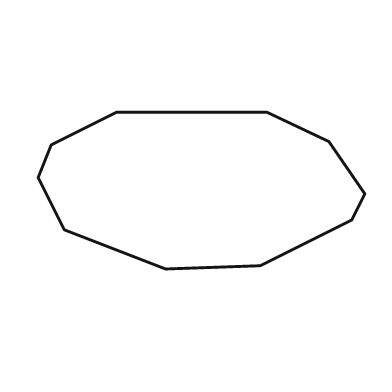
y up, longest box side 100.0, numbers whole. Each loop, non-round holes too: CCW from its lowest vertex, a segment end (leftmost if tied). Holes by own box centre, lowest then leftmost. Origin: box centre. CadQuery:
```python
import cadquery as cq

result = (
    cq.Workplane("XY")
    .moveTo(-11.0, -24.0)
    .lineTo(18.0, -23.0)
    .lineTo(46.0, -9.0)
    .lineTo(50.0, -1.0)
    .lineTo(39.0, 15.0)
    .lineTo(20.0, 24.0)
    .lineTo(-26.0, 24.0)
    .lineTo(-46.0, 14.0)
    .lineTo(-50.0, 4.0)
    .lineTo(-42.0, -12.0)
    .close()
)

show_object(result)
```